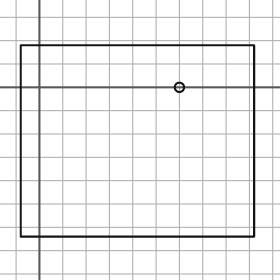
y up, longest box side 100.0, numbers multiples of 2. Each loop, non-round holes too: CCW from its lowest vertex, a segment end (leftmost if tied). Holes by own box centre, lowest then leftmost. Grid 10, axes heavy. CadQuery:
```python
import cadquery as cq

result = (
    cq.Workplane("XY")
    .moveTo(-8.0, -64.0)
    .lineTo(92.0, -64.0)
    .lineTo(92.0, 18.0)
    .lineTo(-8.0, 18.0)
    .close()
    .moveTo(60.0, 0.0)
    .circle(2.0)
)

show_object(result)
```